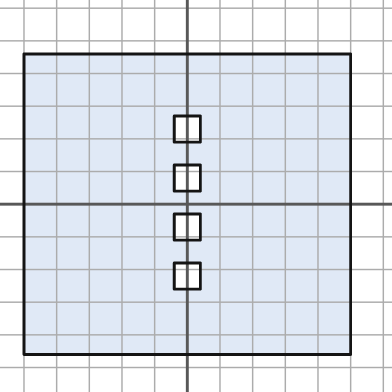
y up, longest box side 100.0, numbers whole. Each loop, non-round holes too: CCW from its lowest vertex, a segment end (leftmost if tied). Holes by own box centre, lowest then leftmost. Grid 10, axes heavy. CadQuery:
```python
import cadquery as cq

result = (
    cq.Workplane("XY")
    .moveTo(-50.0, -46.0)
    .lineTo(50.0, -46.0)
    .lineTo(50.0, 46.0)
    .lineTo(-50.0, 46.0)
    .close()
    .moveTo(-4.0, -26.0)
    .lineTo(4.0, -26.0)
    .lineTo(4.0, -18.0)
    .lineTo(-4.0, -18.0)
    .close()
    .moveTo(-4.0, -11.0)
    .lineTo(4.0, -11.0)
    .lineTo(4.0, -3.0)
    .lineTo(-4.0, -3.0)
    .close()
    .moveTo(-4.0, 4.0)
    .lineTo(4.0, 4.0)
    .lineTo(4.0, 12.0)
    .lineTo(-4.0, 12.0)
    .close()
    .moveTo(-4.0, 19.0)
    .lineTo(4.0, 19.0)
    .lineTo(4.0, 27.0)
    .lineTo(-4.0, 27.0)
    .close()
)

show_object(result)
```